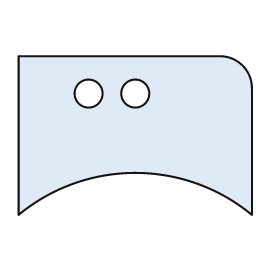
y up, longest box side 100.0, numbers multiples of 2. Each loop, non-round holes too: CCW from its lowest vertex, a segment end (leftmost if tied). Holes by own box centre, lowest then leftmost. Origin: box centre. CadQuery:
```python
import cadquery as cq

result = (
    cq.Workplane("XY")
    .moveTo(-50.0, -34.0)
    .threePointArc((0.0, -16.0), (50.0, -34.0))
    .lineTo(50.0, 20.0)
    .threePointArc((46.0, 30.0), (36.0, 34.0))
    .lineTo(-50.0, 34.0)
    .close()
    .moveTo(-20.0, 18.0)
    .circle(6.0)
    .moveTo(0.0, 18.0)
    .circle(6.0)
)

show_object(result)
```